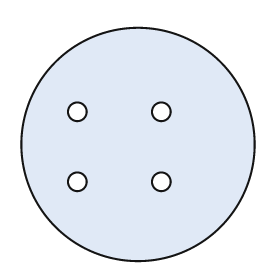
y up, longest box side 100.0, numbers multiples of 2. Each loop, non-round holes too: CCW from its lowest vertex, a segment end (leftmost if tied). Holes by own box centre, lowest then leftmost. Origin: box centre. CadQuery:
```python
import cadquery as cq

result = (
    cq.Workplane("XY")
    .moveTo(0.0, 0.0)
    .circle(50.0)
    .moveTo(-26.0, -16.0)
    .circle(4.0)
    .moveTo(10.0, -16.0)
    .circle(4.0)
    .moveTo(-26.0, 14.0)
    .circle(4.0)
    .moveTo(10.0, 14.0)
    .circle(4.0)
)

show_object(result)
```